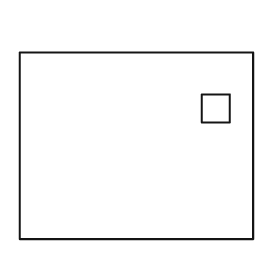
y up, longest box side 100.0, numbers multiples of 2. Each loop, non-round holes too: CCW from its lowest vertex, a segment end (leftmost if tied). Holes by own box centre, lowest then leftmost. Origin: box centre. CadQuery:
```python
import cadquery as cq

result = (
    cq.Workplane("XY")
    .moveTo(-50.0, -40.0)
    .lineTo(50.0, -40.0)
    .lineTo(50.0, 40.0)
    .lineTo(-50.0, 40.0)
    .close()
    .moveTo(28.0, 10.0)
    .lineTo(40.0, 10.0)
    .lineTo(40.0, 22.0)
    .lineTo(28.0, 22.0)
    .close()
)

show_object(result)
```